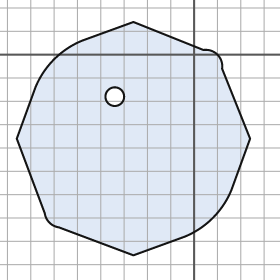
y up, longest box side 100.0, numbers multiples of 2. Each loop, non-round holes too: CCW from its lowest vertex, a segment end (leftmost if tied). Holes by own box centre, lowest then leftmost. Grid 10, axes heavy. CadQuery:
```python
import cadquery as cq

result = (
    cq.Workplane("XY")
    .moveTo(-26.0, -86.0)
    .lineTo(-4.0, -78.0)
    .threePointArc((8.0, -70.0), (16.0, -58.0))
    .lineTo(24.0, -36.0)
    .lineTo(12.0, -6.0)
    .threePointArc((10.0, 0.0), (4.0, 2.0))
    .lineTo(-26.0, 14.0)
    .lineTo(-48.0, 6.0)
    .threePointArc((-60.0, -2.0), (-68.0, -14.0))
    .lineTo(-76.0, -36.0)
    .lineTo(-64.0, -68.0)
    .threePointArc((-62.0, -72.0), (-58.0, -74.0))
    .close()
    .moveTo(-34.0, -18.0)
    .circle(4.0)
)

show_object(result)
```